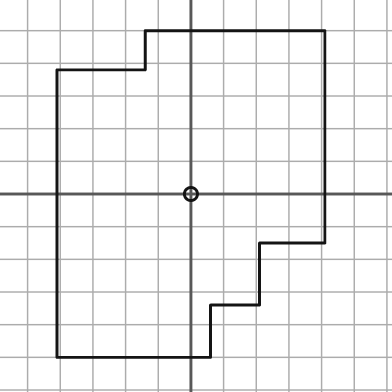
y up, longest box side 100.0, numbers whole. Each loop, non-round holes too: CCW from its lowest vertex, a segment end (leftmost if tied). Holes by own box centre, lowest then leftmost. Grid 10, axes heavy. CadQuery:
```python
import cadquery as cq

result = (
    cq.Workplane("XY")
    .moveTo(-41.0, -50.0)
    .lineTo(6.0, -50.0)
    .lineTo(6.0, -34.0)
    .lineTo(21.0, -34.0)
    .lineTo(21.0, -15.0)
    .lineTo(41.0, -15.0)
    .lineTo(41.0, 50.0)
    .lineTo(-14.0, 50.0)
    .lineTo(-14.0, 38.0)
    .lineTo(-41.0, 38.0)
    .close()
    .moveTo(0.0, 0.0)
    .circle(2.0)
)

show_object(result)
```